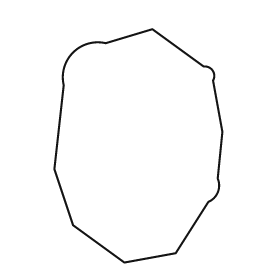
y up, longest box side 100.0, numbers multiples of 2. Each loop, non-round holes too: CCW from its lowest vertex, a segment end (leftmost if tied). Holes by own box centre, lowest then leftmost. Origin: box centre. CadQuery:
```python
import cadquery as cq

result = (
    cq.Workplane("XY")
    .moveTo(-6.0, -50.0)
    .lineTo(16.0, -46.0)
    .lineTo(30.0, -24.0)
    .threePointArc((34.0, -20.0), (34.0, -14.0))
    .lineTo(36.0, 6.0)
    .lineTo(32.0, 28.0)
    .threePointArc((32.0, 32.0), (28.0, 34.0))
    .lineTo(6.0, 50.0)
    .lineTo(-14.0, 44.0)
    .threePointArc((-28.0, 40.0), (-32.0, 26.0))
    .lineTo(-36.0, -10.0)
    .lineTo(-28.0, -34.0)
    .close()
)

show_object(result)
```